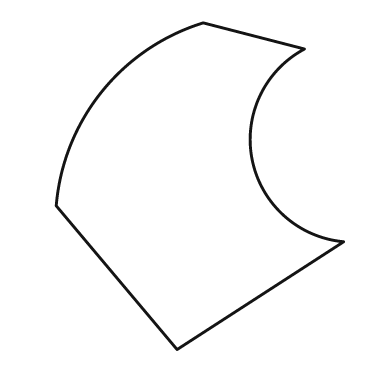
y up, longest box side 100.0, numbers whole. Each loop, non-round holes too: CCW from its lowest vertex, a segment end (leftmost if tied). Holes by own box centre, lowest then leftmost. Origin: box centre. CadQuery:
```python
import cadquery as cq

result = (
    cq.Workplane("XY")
    .moveTo(-7.0, -50.0)
    .lineTo(44.0, -17.0)
    .threePointArc((16.0, 8.0), (32.0, 42.0))
    .lineTo(1.0, 50.0)
    .threePointArc((-30.0, 29.0), (-44.0, -6.0))
    .close()
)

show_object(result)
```